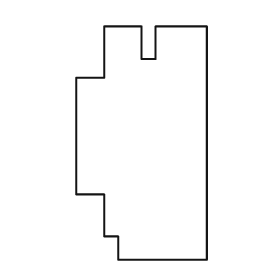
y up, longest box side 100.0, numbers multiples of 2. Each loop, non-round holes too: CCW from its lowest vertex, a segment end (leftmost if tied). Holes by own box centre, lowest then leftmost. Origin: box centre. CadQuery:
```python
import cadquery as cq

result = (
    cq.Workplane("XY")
    .moveTo(-10.0, -50.0)
    .lineTo(28.0, -50.0)
    .lineTo(28.0, 50.0)
    .lineTo(6.0, 50.0)
    .lineTo(6.0, 36.0)
    .lineTo(0.0, 36.0)
    .lineTo(0.0, 50.0)
    .lineTo(-16.0, 50.0)
    .lineTo(-16.0, 28.0)
    .lineTo(-28.0, 28.0)
    .lineTo(-28.0, -22.0)
    .lineTo(-16.0, -22.0)
    .lineTo(-16.0, -40.0)
    .lineTo(-10.0, -40.0)
    .close()
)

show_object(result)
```